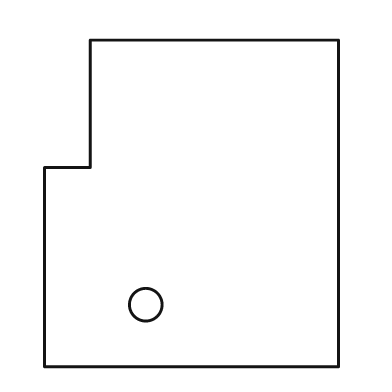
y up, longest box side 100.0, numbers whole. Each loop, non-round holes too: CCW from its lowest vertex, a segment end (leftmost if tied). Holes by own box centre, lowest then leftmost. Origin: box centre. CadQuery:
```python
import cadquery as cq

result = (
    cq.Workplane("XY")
    .moveTo(-45.0, -50.0)
    .lineTo(45.0, -50.0)
    .lineTo(45.0, 50.0)
    .lineTo(-31.0, 50.0)
    .lineTo(-31.0, 11.0)
    .lineTo(-45.0, 11.0)
    .close()
    .moveTo(-14.0, -31.0)
    .circle(5.0)
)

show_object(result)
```